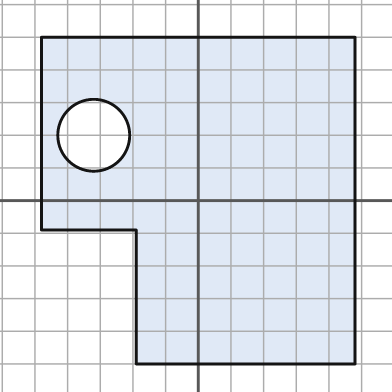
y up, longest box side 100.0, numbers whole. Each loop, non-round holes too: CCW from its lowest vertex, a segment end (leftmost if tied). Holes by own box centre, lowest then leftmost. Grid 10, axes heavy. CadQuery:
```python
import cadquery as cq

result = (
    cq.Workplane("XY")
    .moveTo(-19.0, -50.0)
    .lineTo(48.0, -50.0)
    .lineTo(48.0, 50.0)
    .lineTo(-48.0, 50.0)
    .lineTo(-48.0, -9.0)
    .lineTo(-19.0, -9.0)
    .close()
    .moveTo(-32.0, 20.0)
    .circle(11.0)
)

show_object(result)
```